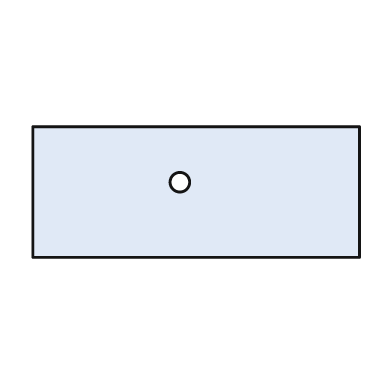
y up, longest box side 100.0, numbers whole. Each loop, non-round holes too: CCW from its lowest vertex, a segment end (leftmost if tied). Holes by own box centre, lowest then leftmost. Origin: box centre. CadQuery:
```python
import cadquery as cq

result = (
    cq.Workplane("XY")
    .moveTo(-50.0, -20.0)
    .lineTo(50.0, -20.0)
    .lineTo(50.0, 20.0)
    .lineTo(-50.0, 20.0)
    .close()
    .moveTo(-5.0, 3.0)
    .circle(3.0)
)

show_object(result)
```